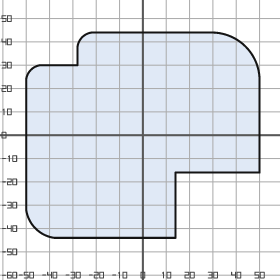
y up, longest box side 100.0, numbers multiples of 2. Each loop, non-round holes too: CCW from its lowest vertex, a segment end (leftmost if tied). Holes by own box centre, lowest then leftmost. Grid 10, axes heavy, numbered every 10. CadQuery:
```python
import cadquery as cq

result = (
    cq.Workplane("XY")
    .moveTo(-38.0, -44.0)
    .lineTo(14.0, -44.0)
    .lineTo(14.0, -16.0)
    .lineTo(50.0, -16.0)
    .lineTo(50.0, 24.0)
    .threePointArc((44.0, 38.0), (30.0, 44.0))
    .lineTo(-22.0, 44.0)
    .threePointArc((-26.0, 42.0), (-28.0, 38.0))
    .lineTo(-28.0, 30.0)
    .lineTo(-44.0, 30.0)
    .threePointArc((-48.0, 28.0), (-50.0, 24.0))
    .lineTo(-50.0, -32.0)
    .threePointArc((-46.0, -40.0), (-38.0, -44.0))
    .close()
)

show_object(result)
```